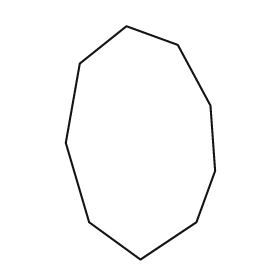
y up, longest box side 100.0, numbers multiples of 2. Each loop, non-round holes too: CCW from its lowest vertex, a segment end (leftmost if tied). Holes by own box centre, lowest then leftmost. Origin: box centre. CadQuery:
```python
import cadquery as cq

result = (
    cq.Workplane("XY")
    .moveTo(0.0, -50.0)
    .lineTo(24.0, -34.0)
    .lineTo(32.0, -12.0)
    .lineTo(30.0, 16.0)
    .lineTo(16.0, 42.0)
    .lineTo(-6.0, 50.0)
    .lineTo(-26.0, 34.0)
    .lineTo(-32.0, 0.0)
    .lineTo(-22.0, -34.0)
    .close()
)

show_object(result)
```